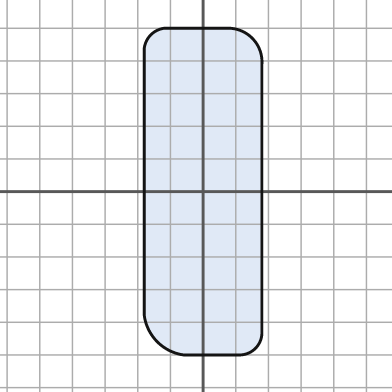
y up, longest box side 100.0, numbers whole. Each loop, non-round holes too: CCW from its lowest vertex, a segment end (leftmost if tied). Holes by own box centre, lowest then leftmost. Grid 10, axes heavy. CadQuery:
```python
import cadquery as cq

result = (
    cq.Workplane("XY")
    .moveTo(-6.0, -50.0)
    .lineTo(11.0, -50.0)
    .threePointArc((16.0, -48.0), (18.0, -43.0))
    .lineTo(18.0, 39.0)
    .threePointArc((15.0, 47.0), (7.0, 50.0))
    .lineTo(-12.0, 50.0)
    .threePointArc((-16.0, 48.0), (-18.0, 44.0))
    .lineTo(-18.0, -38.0)
    .threePointArc((-14.0, -46.0), (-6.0, -50.0))
    .close()
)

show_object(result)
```